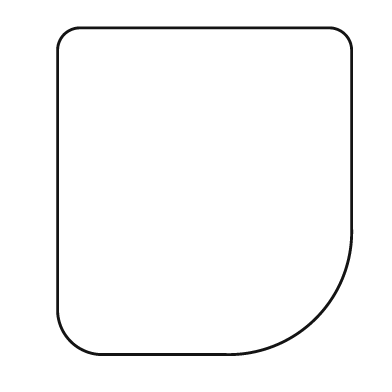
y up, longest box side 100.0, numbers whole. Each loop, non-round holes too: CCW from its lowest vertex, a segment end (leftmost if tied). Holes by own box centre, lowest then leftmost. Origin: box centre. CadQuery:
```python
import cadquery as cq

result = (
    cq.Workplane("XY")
    .moveTo(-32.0, -50.0)
    .lineTo(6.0, -50.0)
    .threePointArc((34.0, -39.0), (45.0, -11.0))
    .lineTo(45.0, 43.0)
    .threePointArc((43.0, 48.0), (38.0, 50.0))
    .lineTo(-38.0, 50.0)
    .threePointArc((-43.0, 48.0), (-45.0, 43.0))
    .lineTo(-45.0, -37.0)
    .threePointArc((-41.0, -46.0), (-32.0, -50.0))
    .close()
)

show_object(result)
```